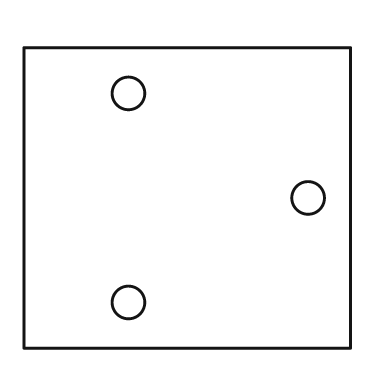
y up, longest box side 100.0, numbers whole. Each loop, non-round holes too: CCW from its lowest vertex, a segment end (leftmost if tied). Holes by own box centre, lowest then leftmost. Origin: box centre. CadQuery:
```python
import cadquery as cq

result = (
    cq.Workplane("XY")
    .moveTo(-50.0, -46.0)
    .lineTo(50.0, -46.0)
    .lineTo(50.0, 46.0)
    .lineTo(-50.0, 46.0)
    .close()
    .moveTo(-18.0, -32.0)
    .circle(5.0)
    .moveTo(37.0, 0.0)
    .circle(5.0)
    .moveTo(-18.0, 32.0)
    .circle(5.0)
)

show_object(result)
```